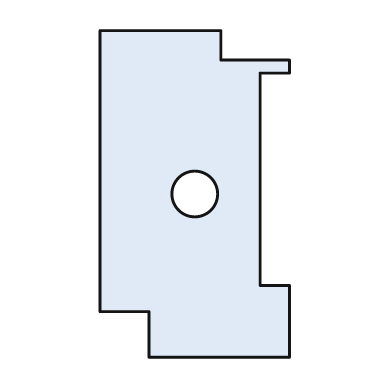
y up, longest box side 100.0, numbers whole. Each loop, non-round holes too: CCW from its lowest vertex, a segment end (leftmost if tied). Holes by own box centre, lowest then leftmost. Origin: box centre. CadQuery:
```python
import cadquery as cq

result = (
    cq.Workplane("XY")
    .moveTo(-14.0, -50.0)
    .lineTo(29.0, -50.0)
    .lineTo(29.0, -28.0)
    .lineTo(20.0, -28.0)
    .lineTo(20.0, 37.0)
    .lineTo(29.0, 37.0)
    .lineTo(29.0, 41.0)
    .lineTo(8.0, 41.0)
    .lineTo(8.0, 50.0)
    .lineTo(-29.0, 50.0)
    .lineTo(-29.0, -36.0)
    .lineTo(-14.0, -36.0)
    .close()
    .moveTo(0.0, 0.0)
    .circle(7.0)
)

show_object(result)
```